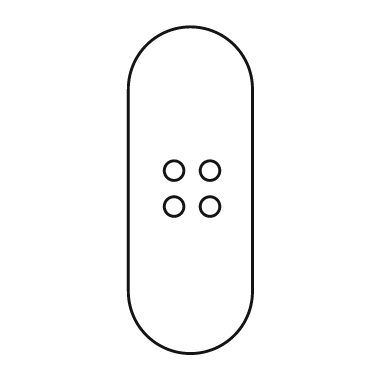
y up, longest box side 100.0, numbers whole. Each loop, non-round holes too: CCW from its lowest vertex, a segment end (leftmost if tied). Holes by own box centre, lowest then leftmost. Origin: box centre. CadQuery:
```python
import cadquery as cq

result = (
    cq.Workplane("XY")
    .moveTo(-19.0, -31.0)
    .threePointArc((0.0, -50.0), (19.0, -31.0))
    .lineTo(19.0, 31.0)
    .threePointArc((0.0, 50.0), (-19.0, 31.0))
    .close()
    .moveTo(-5.0, -5.0)
    .circle(3.0)
    .moveTo(6.0, -5.0)
    .circle(3.0)
    .moveTo(-5.0, 6.0)
    .circle(3.0)
    .moveTo(6.0, 6.0)
    .circle(3.0)
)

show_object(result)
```